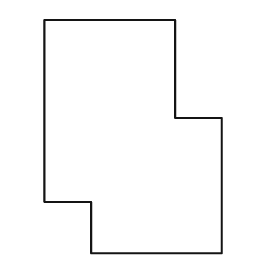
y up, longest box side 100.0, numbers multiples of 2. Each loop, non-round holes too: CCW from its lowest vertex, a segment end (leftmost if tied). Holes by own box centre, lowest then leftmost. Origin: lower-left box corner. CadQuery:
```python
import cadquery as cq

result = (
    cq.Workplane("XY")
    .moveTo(20.0, 0.0)
    .lineTo(76.0, 0.0)
    .lineTo(76.0, 58.0)
    .lineTo(56.0, 58.0)
    .lineTo(56.0, 100.0)
    .lineTo(0.0, 100.0)
    .lineTo(0.0, 22.0)
    .lineTo(20.0, 22.0)
    .close()
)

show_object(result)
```